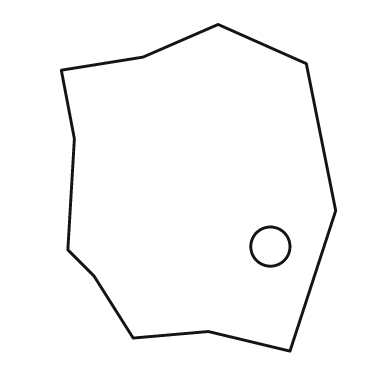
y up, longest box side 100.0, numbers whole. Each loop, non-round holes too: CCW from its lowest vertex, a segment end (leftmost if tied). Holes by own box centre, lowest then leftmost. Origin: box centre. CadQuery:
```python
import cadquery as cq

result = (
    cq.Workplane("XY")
    .moveTo(28.0, -50.0)
    .lineTo(42.0, -7.0)
    .lineTo(33.0, 38.0)
    .lineTo(6.0, 50.0)
    .lineTo(-17.0, 40.0)
    .lineTo(-42.0, 36.0)
    .lineTo(-38.0, 15.0)
    .lineTo(-40.0, -19.0)
    .lineTo(-32.0, -27.0)
    .lineTo(-20.0, -46.0)
    .lineTo(3.0, -44.0)
    .close()
    .moveTo(22.0, -18.0)
    .circle(6.0)
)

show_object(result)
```